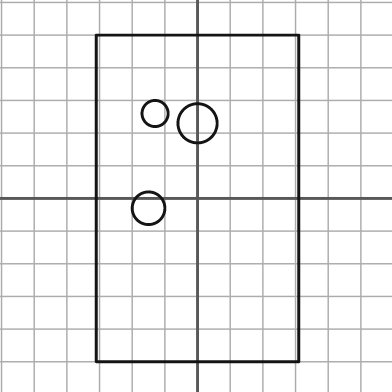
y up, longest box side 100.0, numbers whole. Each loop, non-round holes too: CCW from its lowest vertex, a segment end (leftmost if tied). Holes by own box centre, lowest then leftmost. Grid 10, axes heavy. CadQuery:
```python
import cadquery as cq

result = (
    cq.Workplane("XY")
    .moveTo(-31.0, -50.0)
    .lineTo(31.0, -50.0)
    .lineTo(31.0, 50.0)
    .lineTo(-31.0, 50.0)
    .close()
    .moveTo(-15.0, -3.0)
    .circle(5.0)
    .moveTo(0.0, 23.0)
    .circle(6.0)
    .moveTo(-13.0, 26.0)
    .circle(4.0)
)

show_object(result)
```